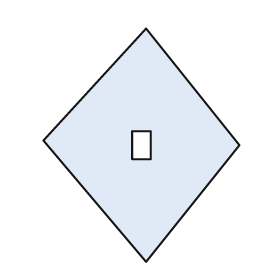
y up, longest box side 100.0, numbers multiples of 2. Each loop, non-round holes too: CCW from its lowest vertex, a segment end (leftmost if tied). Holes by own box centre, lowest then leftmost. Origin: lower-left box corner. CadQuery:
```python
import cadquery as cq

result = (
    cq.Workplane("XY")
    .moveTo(44.0, 0.0)
    .lineTo(84.0, 50.0)
    .lineTo(44.0, 100.0)
    .lineTo(0.0, 52.0)
    .close()
    .moveTo(38.0, 44.0)
    .lineTo(46.0, 44.0)
    .lineTo(46.0, 56.0)
    .lineTo(38.0, 56.0)
    .close()
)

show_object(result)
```